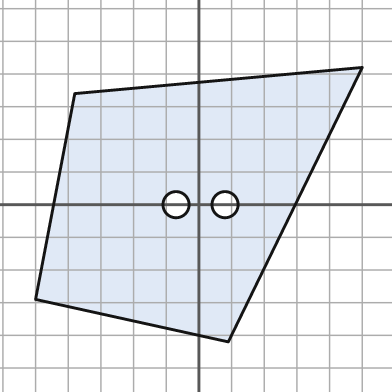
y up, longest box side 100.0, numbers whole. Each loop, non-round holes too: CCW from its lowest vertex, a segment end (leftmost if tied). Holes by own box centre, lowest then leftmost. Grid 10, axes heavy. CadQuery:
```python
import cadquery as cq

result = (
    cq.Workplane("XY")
    .moveTo(9.0, -42.0)
    .lineTo(50.0, 42.0)
    .lineTo(-38.0, 34.0)
    .lineTo(-50.0, -29.0)
    .close()
    .moveTo(-7.0, 0.0)
    .circle(4.0)
    .moveTo(8.0, 0.0)
    .circle(4.0)
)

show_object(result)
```